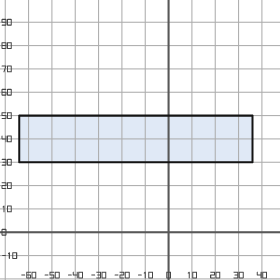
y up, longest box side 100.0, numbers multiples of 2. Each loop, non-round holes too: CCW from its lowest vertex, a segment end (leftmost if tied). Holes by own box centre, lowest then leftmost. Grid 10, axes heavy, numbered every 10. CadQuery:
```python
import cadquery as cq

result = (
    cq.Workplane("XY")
    .moveTo(-64.0, 30.0)
    .lineTo(36.0, 30.0)
    .lineTo(36.0, 50.0)
    .lineTo(-64.0, 50.0)
    .close()
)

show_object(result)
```